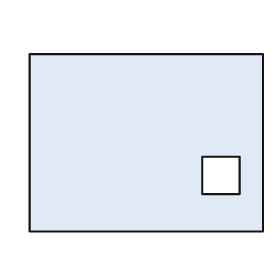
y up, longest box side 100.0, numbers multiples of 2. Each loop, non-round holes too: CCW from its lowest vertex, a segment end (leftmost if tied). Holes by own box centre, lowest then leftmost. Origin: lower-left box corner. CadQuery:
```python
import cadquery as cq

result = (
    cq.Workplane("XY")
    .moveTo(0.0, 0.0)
    .lineTo(100.0, 0.0)
    .lineTo(100.0, 76.0)
    .lineTo(0.0, 76.0)
    .close()
    .moveTo(74.0, 16.0)
    .lineTo(90.0, 16.0)
    .lineTo(90.0, 32.0)
    .lineTo(74.0, 32.0)
    .close()
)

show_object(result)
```